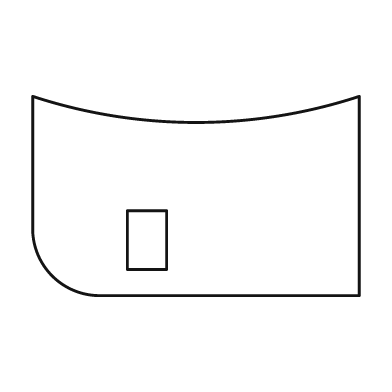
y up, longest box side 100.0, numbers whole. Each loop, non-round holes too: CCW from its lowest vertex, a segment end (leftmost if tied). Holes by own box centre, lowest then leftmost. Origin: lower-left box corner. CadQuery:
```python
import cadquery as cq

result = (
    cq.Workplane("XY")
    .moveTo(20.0, 0.0)
    .lineTo(100.0, 0.0)
    .lineTo(100.0, 61.0)
    .threePointArc((50.0, 53.0), (0.0, 61.0))
    .lineTo(0.0, 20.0)
    .threePointArc((6.0, 6.0), (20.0, 0.0))
    .close()
    .moveTo(29.0, 8.0)
    .lineTo(41.0, 8.0)
    .lineTo(41.0, 26.0)
    .lineTo(29.0, 26.0)
    .close()
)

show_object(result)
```